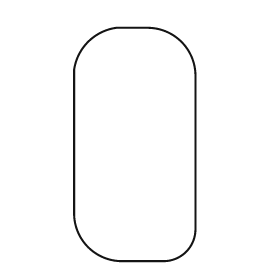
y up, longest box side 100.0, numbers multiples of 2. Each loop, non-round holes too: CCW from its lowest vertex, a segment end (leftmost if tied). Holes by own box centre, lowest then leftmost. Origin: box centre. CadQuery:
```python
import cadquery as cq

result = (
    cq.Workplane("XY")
    .moveTo(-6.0, -50.0)
    .lineTo(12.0, -50.0)
    .threePointArc((22.0, -46.0), (26.0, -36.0))
    .lineTo(26.0, 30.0)
    .threePointArc((20.0, 44.0), (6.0, 50.0))
    .lineTo(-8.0, 50.0)
    .threePointArc((-20.0, 44.0), (-26.0, 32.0))
    .lineTo(-26.0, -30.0)
    .threePointArc((-20.0, -44.0), (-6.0, -50.0))
    .close()
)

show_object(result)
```